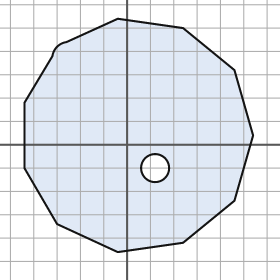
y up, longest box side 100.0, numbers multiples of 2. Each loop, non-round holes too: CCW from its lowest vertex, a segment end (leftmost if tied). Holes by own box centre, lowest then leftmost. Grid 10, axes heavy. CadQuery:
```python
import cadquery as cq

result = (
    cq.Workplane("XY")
    .moveTo(-4.0, -46.0)
    .lineTo(24.0, -42.0)
    .lineTo(46.0, -24.0)
    .lineTo(54.0, 4.0)
    .lineTo(46.0, 32.0)
    .lineTo(24.0, 50.0)
    .lineTo(-4.0, 54.0)
    .lineTo(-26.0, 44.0)
    .threePointArc((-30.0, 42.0), (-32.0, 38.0))
    .lineTo(-44.0, 18.0)
    .lineTo(-44.0, -10.0)
    .lineTo(-30.0, -34.0)
    .close()
    .moveTo(12.0, -10.0)
    .circle(6.0)
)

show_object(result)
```